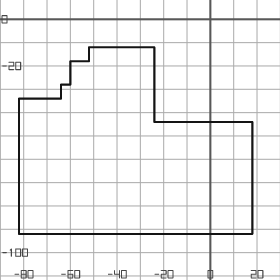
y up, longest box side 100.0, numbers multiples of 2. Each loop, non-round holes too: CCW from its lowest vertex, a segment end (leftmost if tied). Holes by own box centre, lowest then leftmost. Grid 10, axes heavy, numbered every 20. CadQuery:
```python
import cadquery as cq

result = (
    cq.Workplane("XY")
    .moveTo(-82.0, -92.0)
    .lineTo(18.0, -92.0)
    .lineTo(18.0, -44.0)
    .lineTo(-24.0, -44.0)
    .lineTo(-24.0, -12.0)
    .lineTo(-52.0, -12.0)
    .lineTo(-52.0, -18.0)
    .lineTo(-60.0, -18.0)
    .lineTo(-60.0, -28.0)
    .lineTo(-64.0, -28.0)
    .lineTo(-64.0, -34.0)
    .lineTo(-82.0, -34.0)
    .close()
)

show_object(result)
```